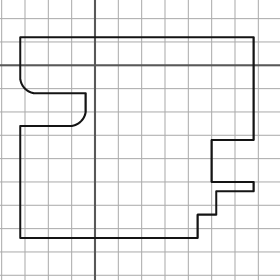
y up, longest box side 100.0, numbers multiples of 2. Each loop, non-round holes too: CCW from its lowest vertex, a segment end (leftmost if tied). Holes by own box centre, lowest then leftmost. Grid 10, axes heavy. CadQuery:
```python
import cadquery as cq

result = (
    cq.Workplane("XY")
    .moveTo(-32.0, -74.0)
    .lineTo(44.0, -74.0)
    .lineTo(44.0, -64.0)
    .lineTo(52.0, -64.0)
    .lineTo(52.0, -54.0)
    .lineTo(68.0, -54.0)
    .lineTo(68.0, -50.0)
    .lineTo(50.0, -50.0)
    .lineTo(50.0, -32.0)
    .lineTo(68.0, -32.0)
    .lineTo(68.0, 12.0)
    .lineTo(-32.0, 12.0)
    .lineTo(-32.0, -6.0)
    .threePointArc((-30.0, -10.0), (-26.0, -12.0))
    .lineTo(-4.0, -12.0)
    .lineTo(-4.0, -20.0)
    .threePointArc((-6.0, -24.0), (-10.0, -26.0))
    .lineTo(-32.0, -26.0)
    .close()
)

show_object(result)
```